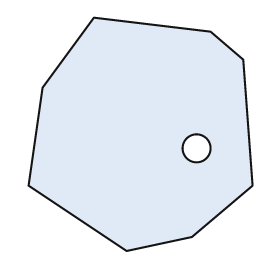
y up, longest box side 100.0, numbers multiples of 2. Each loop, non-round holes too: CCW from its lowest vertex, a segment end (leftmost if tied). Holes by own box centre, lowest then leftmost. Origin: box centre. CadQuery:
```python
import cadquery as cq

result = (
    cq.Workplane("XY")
    .moveTo(-6.0, -50.0)
    .lineTo(22.0, -44.0)
    .lineTo(48.0, -22.0)
    .lineTo(44.0, 32.0)
    .lineTo(30.0, 44.0)
    .lineTo(-20.0, 50.0)
    .lineTo(-42.0, 20.0)
    .lineTo(-48.0, -22.0)
    .close()
    .moveTo(24.0, -6.0)
    .circle(6.0)
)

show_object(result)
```